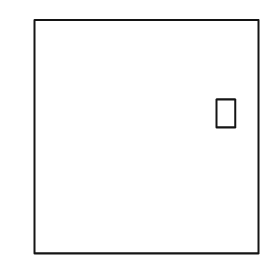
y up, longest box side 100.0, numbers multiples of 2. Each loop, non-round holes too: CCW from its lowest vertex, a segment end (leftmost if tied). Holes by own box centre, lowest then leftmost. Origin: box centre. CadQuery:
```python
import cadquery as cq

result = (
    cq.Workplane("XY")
    .moveTo(-48.0, -50.0)
    .lineTo(48.0, -50.0)
    .lineTo(48.0, 50.0)
    .lineTo(-48.0, 50.0)
    .close()
    .moveTo(30.0, 4.0)
    .lineTo(38.0, 4.0)
    .lineTo(38.0, 16.0)
    .lineTo(30.0, 16.0)
    .close()
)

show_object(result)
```